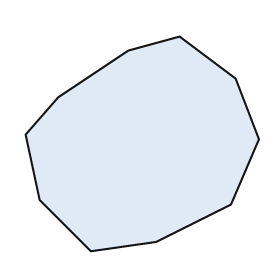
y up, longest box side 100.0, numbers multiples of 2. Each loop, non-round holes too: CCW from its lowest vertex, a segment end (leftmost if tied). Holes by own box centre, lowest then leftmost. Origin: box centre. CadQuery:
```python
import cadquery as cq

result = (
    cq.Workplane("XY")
    .moveTo(-22.0, -46.0)
    .lineTo(6.0, -42.0)
    .lineTo(38.0, -26.0)
    .lineTo(50.0, 2.0)
    .lineTo(40.0, 28.0)
    .lineTo(16.0, 46.0)
    .lineTo(-6.0, 40.0)
    .lineTo(-36.0, 20.0)
    .lineTo(-50.0, 4.0)
    .lineTo(-44.0, -24.0)
    .close()
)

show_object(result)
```